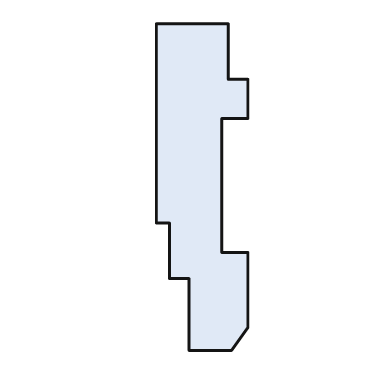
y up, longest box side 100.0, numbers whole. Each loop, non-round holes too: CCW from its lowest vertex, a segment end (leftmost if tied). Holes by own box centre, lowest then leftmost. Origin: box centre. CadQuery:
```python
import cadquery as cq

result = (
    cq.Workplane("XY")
    .moveTo(-4.0, -50.0)
    .lineTo(9.0, -50.0)
    .lineTo(14.0, -43.0)
    .lineTo(14.0, -20.0)
    .lineTo(6.0, -20.0)
    .lineTo(6.0, 21.0)
    .lineTo(14.0, 21.0)
    .lineTo(14.0, 33.0)
    .lineTo(8.0, 33.0)
    .lineTo(8.0, 50.0)
    .lineTo(-14.0, 50.0)
    .lineTo(-14.0, -11.0)
    .lineTo(-10.0, -11.0)
    .lineTo(-10.0, -28.0)
    .lineTo(-4.0, -28.0)
    .close()
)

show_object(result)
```